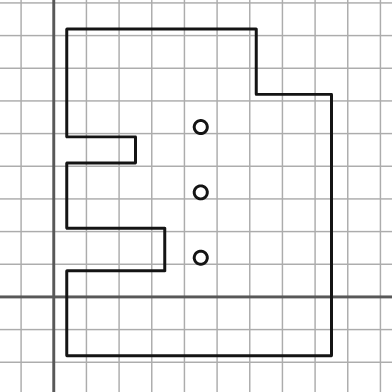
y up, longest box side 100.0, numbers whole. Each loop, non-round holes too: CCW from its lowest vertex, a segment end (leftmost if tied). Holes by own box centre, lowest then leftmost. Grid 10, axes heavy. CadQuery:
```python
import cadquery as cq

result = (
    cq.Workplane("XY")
    .moveTo(4.0, -18.0)
    .lineTo(85.0, -18.0)
    .lineTo(85.0, 62.0)
    .lineTo(62.0, 62.0)
    .lineTo(62.0, 82.0)
    .lineTo(4.0, 82.0)
    .lineTo(4.0, 49.0)
    .lineTo(25.0, 49.0)
    .lineTo(25.0, 41.0)
    .lineTo(4.0, 41.0)
    .lineTo(4.0, 21.0)
    .lineTo(34.0, 21.0)
    .lineTo(34.0, 8.0)
    .lineTo(4.0, 8.0)
    .close()
    .moveTo(45.0, 12.0)
    .circle(2.0)
    .moveTo(45.0, 32.0)
    .circle(2.0)
    .moveTo(45.0, 52.0)
    .circle(2.0)
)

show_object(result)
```